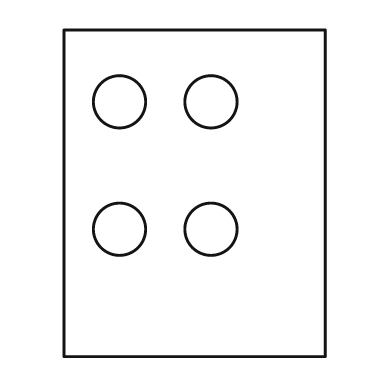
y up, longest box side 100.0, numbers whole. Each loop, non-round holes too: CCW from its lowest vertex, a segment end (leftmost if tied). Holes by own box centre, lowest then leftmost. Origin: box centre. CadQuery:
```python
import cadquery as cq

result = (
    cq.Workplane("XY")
    .moveTo(-40.0, -50.0)
    .lineTo(40.0, -50.0)
    .lineTo(40.0, 50.0)
    .lineTo(-40.0, 50.0)
    .close()
    .moveTo(-23.0, -11.0)
    .circle(8.0)
    .moveTo(5.0, -11.0)
    .circle(8.0)
    .moveTo(-23.0, 28.0)
    .circle(8.0)
    .moveTo(5.0, 28.0)
    .circle(8.0)
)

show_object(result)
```